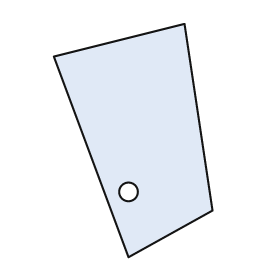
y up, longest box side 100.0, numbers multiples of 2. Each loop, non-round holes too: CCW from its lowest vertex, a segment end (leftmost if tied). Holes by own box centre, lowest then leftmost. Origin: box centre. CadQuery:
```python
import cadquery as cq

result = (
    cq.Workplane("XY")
    .moveTo(-2.0, -50.0)
    .lineTo(34.0, -30.0)
    .lineTo(22.0, 50.0)
    .lineTo(-34.0, 36.0)
    .close()
    .moveTo(-2.0, -22.0)
    .circle(4.0)
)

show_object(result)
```